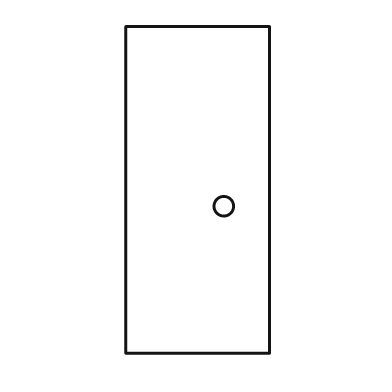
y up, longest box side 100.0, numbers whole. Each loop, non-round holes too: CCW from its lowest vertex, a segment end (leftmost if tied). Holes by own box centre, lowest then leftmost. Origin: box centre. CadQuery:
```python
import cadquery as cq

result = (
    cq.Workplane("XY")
    .moveTo(-22.0, -50.0)
    .lineTo(22.0, -50.0)
    .lineTo(22.0, 50.0)
    .lineTo(-22.0, 50.0)
    .close()
    .moveTo(8.0, -5.0)
    .circle(3.0)
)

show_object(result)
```